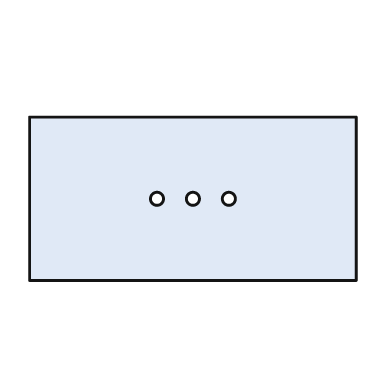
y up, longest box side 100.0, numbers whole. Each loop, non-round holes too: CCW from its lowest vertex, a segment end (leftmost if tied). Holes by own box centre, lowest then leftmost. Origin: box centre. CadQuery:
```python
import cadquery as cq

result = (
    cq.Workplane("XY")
    .moveTo(-50.0, -25.0)
    .lineTo(50.0, -25.0)
    .lineTo(50.0, 25.0)
    .lineTo(-50.0, 25.0)
    .close()
    .moveTo(-11.0, 0.0)
    .circle(2.0)
    .moveTo(0.0, 0.0)
    .circle(2.0)
    .moveTo(11.0, 0.0)
    .circle(2.0)
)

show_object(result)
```